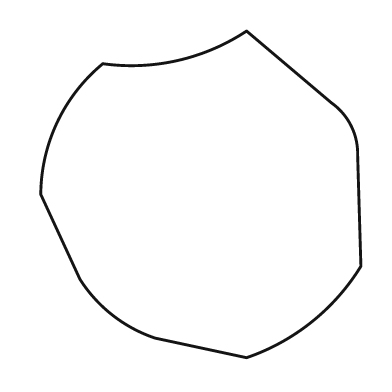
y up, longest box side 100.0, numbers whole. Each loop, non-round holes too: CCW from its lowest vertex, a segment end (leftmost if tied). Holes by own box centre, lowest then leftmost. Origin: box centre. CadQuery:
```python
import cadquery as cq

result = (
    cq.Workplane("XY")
    .moveTo(14.0, -50.0)
    .threePointArc((34.0, -39.0), (49.0, -22.0))
    .lineTo(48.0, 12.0)
    .threePointArc((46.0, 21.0), (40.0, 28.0))
    .lineTo(14.0, 50.0)
    .threePointArc((-7.0, 41.0), (-30.0, 40.0))
    .threePointArc((-44.0, 22.0), (-49.0, 0.0))
    .lineTo(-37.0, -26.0)
    .threePointArc((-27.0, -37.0), (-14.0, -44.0))
    .close()
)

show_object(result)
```